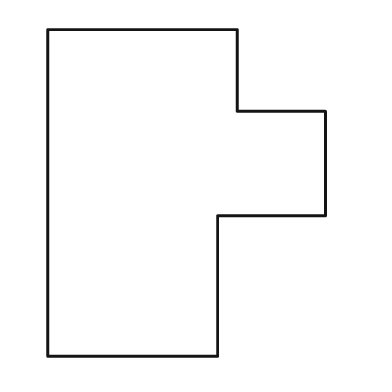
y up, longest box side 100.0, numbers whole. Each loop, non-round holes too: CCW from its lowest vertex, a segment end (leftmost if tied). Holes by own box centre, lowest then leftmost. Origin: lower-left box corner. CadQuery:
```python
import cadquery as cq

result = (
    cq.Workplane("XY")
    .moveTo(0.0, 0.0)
    .lineTo(52.0, 0.0)
    .lineTo(52.0, 43.0)
    .lineTo(85.0, 43.0)
    .lineTo(85.0, 75.0)
    .lineTo(58.0, 75.0)
    .lineTo(58.0, 100.0)
    .lineTo(0.0, 100.0)
    .close()
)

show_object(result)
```